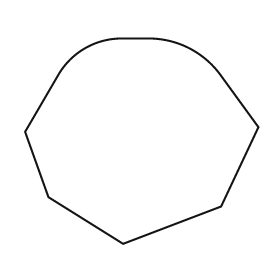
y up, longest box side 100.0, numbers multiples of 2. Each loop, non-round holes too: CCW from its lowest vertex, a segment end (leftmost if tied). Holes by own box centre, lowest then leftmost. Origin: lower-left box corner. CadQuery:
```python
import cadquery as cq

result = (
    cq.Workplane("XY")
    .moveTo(42.0, 0.0)
    .lineTo(84.0, 16.0)
    .lineTo(100.0, 50.0)
    .lineTo(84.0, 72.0)
    .threePointArc((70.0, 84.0), (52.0, 88.0))
    .lineTo(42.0, 88.0)
    .threePointArc((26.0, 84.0), (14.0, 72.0))
    .lineTo(0.0, 48.0)
    .lineTo(10.0, 20.0)
    .close()
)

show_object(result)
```